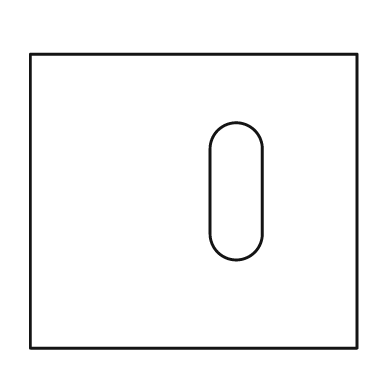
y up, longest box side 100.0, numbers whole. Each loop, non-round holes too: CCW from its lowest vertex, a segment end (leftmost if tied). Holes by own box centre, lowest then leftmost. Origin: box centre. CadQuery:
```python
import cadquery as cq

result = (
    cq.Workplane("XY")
    .moveTo(-50.0, -45.0)
    .lineTo(50.0, -45.0)
    .lineTo(50.0, 45.0)
    .lineTo(-50.0, 45.0)
    .close()
    .moveTo(5.0, -10.0)
    .threePointArc((13.0, -18.0), (21.0, -10.0))
    .lineTo(21.0, 16.0)
    .threePointArc((13.0, 24.0), (5.0, 16.0))
    .close()
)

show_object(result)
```